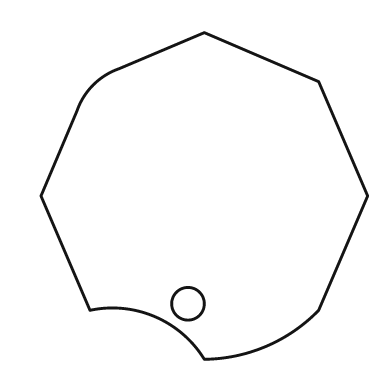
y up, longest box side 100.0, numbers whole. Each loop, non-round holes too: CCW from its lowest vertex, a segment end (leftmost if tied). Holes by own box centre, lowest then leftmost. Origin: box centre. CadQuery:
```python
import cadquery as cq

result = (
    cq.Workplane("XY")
    .moveTo(0.0, -50.0)
    .threePointArc((19.0, -46.0), (35.0, -35.0))
    .lineTo(50.0, 0.0)
    .lineTo(35.0, 35.0)
    .lineTo(0.0, 50.0)
    .lineTo(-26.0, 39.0)
    .threePointArc((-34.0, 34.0), (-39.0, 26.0))
    .lineTo(-50.0, 0.0)
    .lineTo(-35.0, -35.0)
    .threePointArc((-15.0, -37.0), (0.0, -50.0))
    .close()
    .moveTo(-5.0, -33.0)
    .circle(5.0)
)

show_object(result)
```